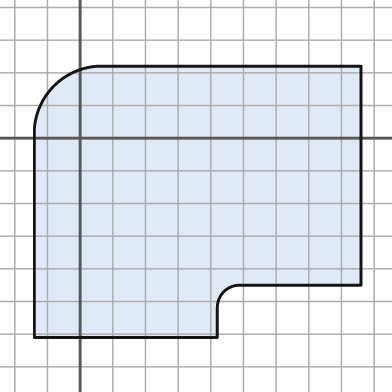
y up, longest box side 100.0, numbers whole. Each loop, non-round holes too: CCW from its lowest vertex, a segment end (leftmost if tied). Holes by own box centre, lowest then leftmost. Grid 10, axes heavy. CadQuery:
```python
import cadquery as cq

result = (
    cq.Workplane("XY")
    .moveTo(-14.0, -61.0)
    .lineTo(42.0, -61.0)
    .lineTo(42.0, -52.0)
    .threePointArc((44.0, -47.0), (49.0, -45.0))
    .lineTo(86.0, -45.0)
    .lineTo(86.0, 22.0)
    .lineTo(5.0, 22.0)
    .threePointArc((-8.0, 16.0), (-14.0, 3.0))
    .close()
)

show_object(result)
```